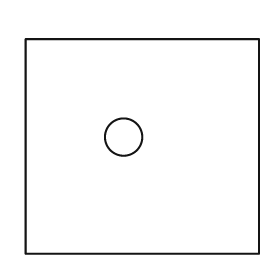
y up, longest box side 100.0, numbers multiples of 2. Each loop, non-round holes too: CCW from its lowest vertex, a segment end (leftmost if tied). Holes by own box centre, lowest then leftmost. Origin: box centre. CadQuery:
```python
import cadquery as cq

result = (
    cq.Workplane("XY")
    .moveTo(-50.0, -46.0)
    .lineTo(50.0, -46.0)
    .lineTo(50.0, 46.0)
    .lineTo(-50.0, 46.0)
    .close()
    .moveTo(-8.0, 4.0)
    .circle(8.0)
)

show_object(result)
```